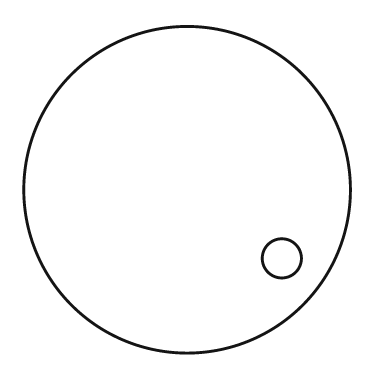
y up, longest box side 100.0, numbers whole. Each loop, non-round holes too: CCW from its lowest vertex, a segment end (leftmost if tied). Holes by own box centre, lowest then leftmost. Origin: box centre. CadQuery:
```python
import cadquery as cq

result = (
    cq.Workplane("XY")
    .moveTo(0.0, 0.0)
    .circle(50.0)
    .moveTo(29.0, -21.0)
    .circle(6.0)
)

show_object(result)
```